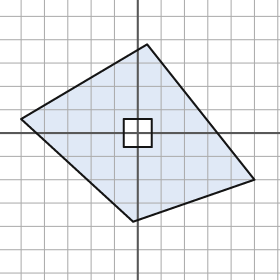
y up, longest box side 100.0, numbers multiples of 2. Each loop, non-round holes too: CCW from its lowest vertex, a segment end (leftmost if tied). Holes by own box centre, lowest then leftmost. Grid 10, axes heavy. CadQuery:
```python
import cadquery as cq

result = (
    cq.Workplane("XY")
    .moveTo(-2.0, -38.0)
    .lineTo(50.0, -20.0)
    .lineTo(4.0, 38.0)
    .lineTo(-50.0, 6.0)
    .close()
    .moveTo(-6.0, -6.0)
    .lineTo(6.0, -6.0)
    .lineTo(6.0, 6.0)
    .lineTo(-6.0, 6.0)
    .close()
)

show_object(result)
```